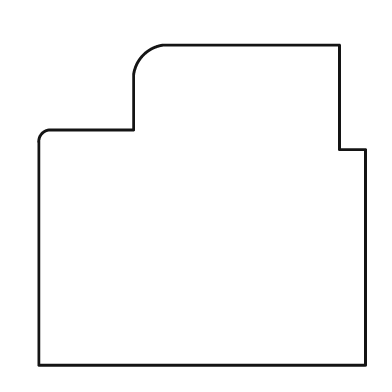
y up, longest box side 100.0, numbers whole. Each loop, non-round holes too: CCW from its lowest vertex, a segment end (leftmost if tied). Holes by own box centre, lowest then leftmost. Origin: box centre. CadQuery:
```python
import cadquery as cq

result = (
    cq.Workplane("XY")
    .moveTo(-50.0, -49.0)
    .lineTo(50.0, -49.0)
    .lineTo(50.0, 17.0)
    .lineTo(42.0, 17.0)
    .lineTo(42.0, 49.0)
    .lineTo(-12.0, 49.0)
    .threePointArc((-18.0, 46.0), (-21.0, 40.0))
    .lineTo(-21.0, 23.0)
    .lineTo(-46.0, 23.0)
    .threePointArc((-49.0, 22.0), (-50.0, 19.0))
    .close()
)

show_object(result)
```